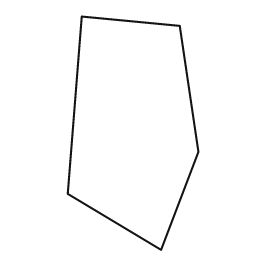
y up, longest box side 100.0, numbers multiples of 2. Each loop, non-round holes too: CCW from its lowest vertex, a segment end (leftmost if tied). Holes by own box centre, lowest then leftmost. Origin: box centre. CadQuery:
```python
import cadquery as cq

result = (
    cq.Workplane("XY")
    .moveTo(12.0, -50.0)
    .lineTo(28.0, -8.0)
    .lineTo(20.0, 46.0)
    .lineTo(-22.0, 50.0)
    .lineTo(-28.0, -26.0)
    .close()
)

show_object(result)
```